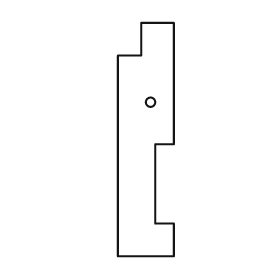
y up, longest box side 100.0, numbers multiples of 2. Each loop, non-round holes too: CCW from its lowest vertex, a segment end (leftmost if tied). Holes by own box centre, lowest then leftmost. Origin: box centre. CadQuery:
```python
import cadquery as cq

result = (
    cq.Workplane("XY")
    .moveTo(-12.0, -50.0)
    .lineTo(12.0, -50.0)
    .lineTo(12.0, -36.0)
    .lineTo(4.0, -36.0)
    .lineTo(4.0, -2.0)
    .lineTo(12.0, -2.0)
    .lineTo(12.0, 50.0)
    .lineTo(-2.0, 50.0)
    .lineTo(-2.0, 36.0)
    .lineTo(-12.0, 36.0)
    .close()
    .moveTo(2.0, 16.0)
    .circle(2.0)
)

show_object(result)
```